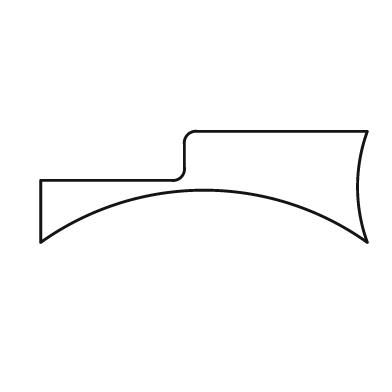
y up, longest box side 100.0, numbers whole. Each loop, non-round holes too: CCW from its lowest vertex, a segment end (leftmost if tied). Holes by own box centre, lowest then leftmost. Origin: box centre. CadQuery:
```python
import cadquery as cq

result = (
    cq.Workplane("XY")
    .moveTo(-50.0, -17.0)
    .threePointArc((0.0, -1.0), (50.0, -17.0))
    .threePointArc((47.0, 0.0), (50.0, 17.0))
    .lineTo(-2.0, 17.0)
    .threePointArc((-5.0, 16.0), (-6.0, 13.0))
    .lineTo(-6.0, 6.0)
    .threePointArc((-7.0, 3.0), (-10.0, 2.0))
    .lineTo(-50.0, 2.0)
    .close()
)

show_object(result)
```